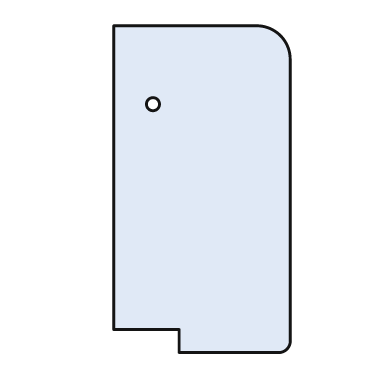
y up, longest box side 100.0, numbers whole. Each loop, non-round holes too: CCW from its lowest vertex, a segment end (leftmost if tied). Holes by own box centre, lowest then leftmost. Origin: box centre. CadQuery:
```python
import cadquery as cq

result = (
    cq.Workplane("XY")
    .moveTo(-7.0, -50.0)
    .lineTo(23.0, -50.0)
    .threePointArc((26.0, -49.0), (27.0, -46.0))
    .lineTo(27.0, 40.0)
    .threePointArc((24.0, 47.0), (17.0, 50.0))
    .lineTo(-27.0, 50.0)
    .lineTo(-27.0, -43.0)
    .lineTo(-7.0, -43.0)
    .close()
    .moveTo(-15.0, 26.0)
    .circle(2.0)
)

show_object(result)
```